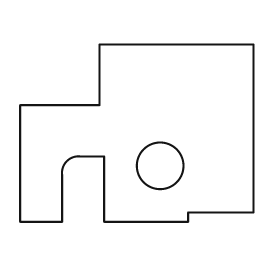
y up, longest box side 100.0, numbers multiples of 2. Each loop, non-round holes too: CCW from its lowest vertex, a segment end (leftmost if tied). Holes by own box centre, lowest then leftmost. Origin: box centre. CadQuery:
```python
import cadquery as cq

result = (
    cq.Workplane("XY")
    .moveTo(-50.0, -38.0)
    .lineTo(-32.0, -38.0)
    .lineTo(-32.0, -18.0)
    .threePointArc((-30.0, -12.0), (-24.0, -10.0))
    .lineTo(-14.0, -10.0)
    .lineTo(-14.0, -38.0)
    .lineTo(22.0, -38.0)
    .lineTo(22.0, -34.0)
    .lineTo(50.0, -34.0)
    .lineTo(50.0, 38.0)
    .lineTo(-16.0, 38.0)
    .lineTo(-16.0, 12.0)
    .lineTo(-50.0, 12.0)
    .close()
    .moveTo(10.0, -14.0)
    .circle(10.0)
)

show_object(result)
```